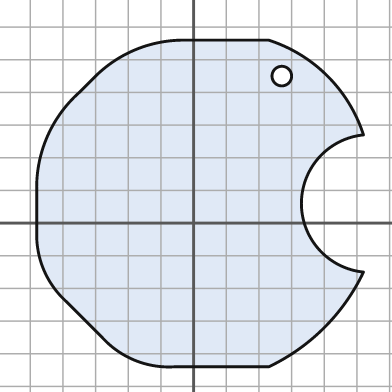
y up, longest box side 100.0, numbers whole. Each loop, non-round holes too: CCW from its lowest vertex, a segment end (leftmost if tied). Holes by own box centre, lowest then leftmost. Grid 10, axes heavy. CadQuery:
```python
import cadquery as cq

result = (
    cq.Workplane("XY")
    .moveTo(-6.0, -44.0)
    .lineTo(23.0, -44.0)
    .threePointArc((40.0, -32.0), (52.0, -15.0))
    .threePointArc((33.0, 6.0), (52.0, 27.0))
    .threePointArc((41.0, 45.0), (23.0, 56.0))
    .lineTo(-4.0, 56.0)
    .threePointArc((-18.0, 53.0), (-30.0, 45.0))
    .lineTo(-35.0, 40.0)
    .threePointArc((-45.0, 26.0), (-48.0, 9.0))
    .lineTo(-48.0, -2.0)
    .threePointArc((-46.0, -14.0), (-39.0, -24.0))
    .lineTo(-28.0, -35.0)
    .threePointArc((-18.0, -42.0), (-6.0, -44.0))
    .close()
    .moveTo(27.0, 45.0)
    .circle(3.0)
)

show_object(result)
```